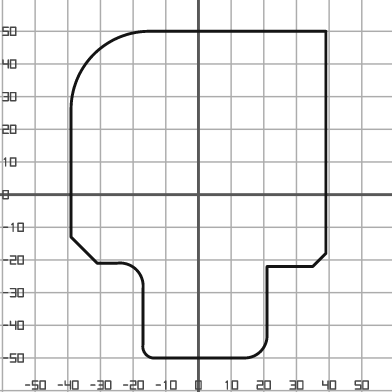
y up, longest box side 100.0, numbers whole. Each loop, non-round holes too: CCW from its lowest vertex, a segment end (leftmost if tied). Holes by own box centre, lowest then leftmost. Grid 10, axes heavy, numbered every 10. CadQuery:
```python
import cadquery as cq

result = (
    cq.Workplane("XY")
    .moveTo(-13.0, -50.0)
    .lineTo(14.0, -50.0)
    .threePointArc((19.0, -48.0), (21.0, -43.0))
    .lineTo(21.0, -22.0)
    .lineTo(35.0, -22.0)
    .lineTo(39.0, -18.0)
    .lineTo(39.0, 50.0)
    .lineTo(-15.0, 50.0)
    .threePointArc((-32.0, 43.0), (-39.0, 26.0))
    .lineTo(-39.0, -13.0)
    .lineTo(-31.0, -21.0)
    .lineTo(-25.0, -21.0)
    .threePointArc((-19.0, -23.0), (-17.0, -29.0))
    .lineTo(-17.0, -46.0)
    .threePointArc((-16.0, -49.0), (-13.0, -50.0))
    .close()
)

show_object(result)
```